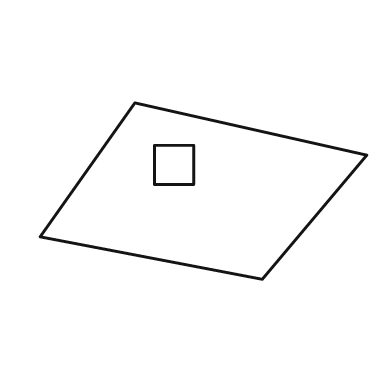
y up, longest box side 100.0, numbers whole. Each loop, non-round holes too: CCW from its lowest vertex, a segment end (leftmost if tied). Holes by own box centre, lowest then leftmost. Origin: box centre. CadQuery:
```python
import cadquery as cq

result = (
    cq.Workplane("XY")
    .moveTo(18.0, -27.0)
    .lineTo(50.0, 11.0)
    .lineTo(-21.0, 27.0)
    .lineTo(-50.0, -14.0)
    .close()
    .moveTo(-15.0, 2.0)
    .lineTo(-3.0, 2.0)
    .lineTo(-3.0, 14.0)
    .lineTo(-15.0, 14.0)
    .close()
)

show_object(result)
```